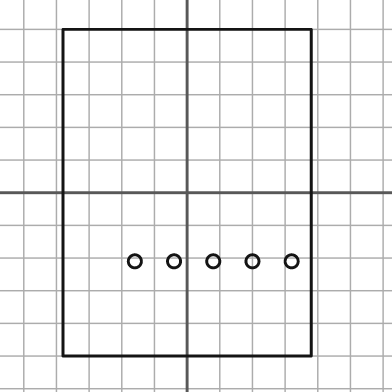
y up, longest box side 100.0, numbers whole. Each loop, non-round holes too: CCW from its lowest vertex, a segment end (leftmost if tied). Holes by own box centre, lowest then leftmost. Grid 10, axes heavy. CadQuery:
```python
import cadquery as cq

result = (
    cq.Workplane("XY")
    .moveTo(-38.0, -50.0)
    .lineTo(38.0, -50.0)
    .lineTo(38.0, 50.0)
    .lineTo(-38.0, 50.0)
    .close()
    .moveTo(-16.0, -21.0)
    .circle(2.0)
    .moveTo(-4.0, -21.0)
    .circle(2.0)
    .moveTo(8.0, -21.0)
    .circle(2.0)
    .moveTo(20.0, -21.0)
    .circle(2.0)
    .moveTo(32.0, -21.0)
    .circle(2.0)
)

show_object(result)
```